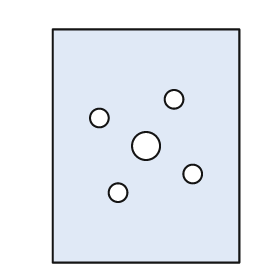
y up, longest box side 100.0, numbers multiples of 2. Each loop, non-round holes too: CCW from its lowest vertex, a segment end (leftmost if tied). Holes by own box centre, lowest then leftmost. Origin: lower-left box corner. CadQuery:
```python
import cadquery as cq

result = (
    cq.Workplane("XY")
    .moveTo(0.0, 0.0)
    .lineTo(80.0, 0.0)
    .lineTo(80.0, 100.0)
    .lineTo(0.0, 100.0)
    .close()
    .moveTo(28.0, 30.0)
    .circle(4.0)
    .moveTo(60.0, 38.0)
    .circle(4.0)
    .moveTo(40.0, 50.0)
    .circle(6.0)
    .moveTo(20.0, 62.0)
    .circle(4.0)
    .moveTo(52.0, 70.0)
    .circle(4.0)
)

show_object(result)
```